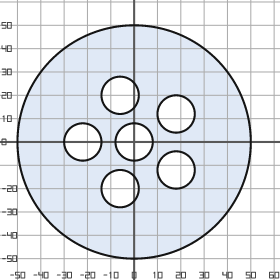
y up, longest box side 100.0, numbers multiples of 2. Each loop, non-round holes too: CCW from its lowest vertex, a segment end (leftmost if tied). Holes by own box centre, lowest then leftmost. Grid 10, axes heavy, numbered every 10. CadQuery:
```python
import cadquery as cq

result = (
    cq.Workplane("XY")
    .moveTo(0.0, 0.0)
    .circle(50.0)
    .moveTo(-6.0, -20.0)
    .circle(8.0)
    .moveTo(18.0, -12.0)
    .circle(8.0)
    .moveTo(-22.0, 0.0)
    .circle(8.0)
    .moveTo(0.0, 0.0)
    .circle(8.0)
    .moveTo(18.0, 12.0)
    .circle(8.0)
    .moveTo(-6.0, 20.0)
    .circle(8.0)
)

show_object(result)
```